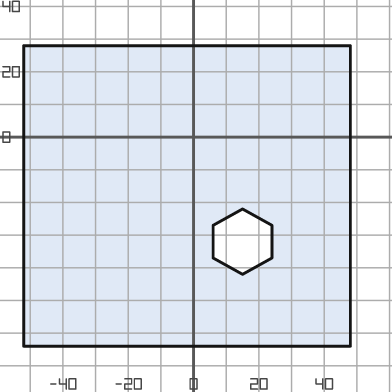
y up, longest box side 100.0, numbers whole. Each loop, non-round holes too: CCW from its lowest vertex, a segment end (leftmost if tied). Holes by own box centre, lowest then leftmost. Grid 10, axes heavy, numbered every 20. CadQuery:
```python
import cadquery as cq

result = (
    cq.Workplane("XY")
    .moveTo(-52.0, -64.0)
    .lineTo(48.0, -64.0)
    .lineTo(48.0, 28.0)
    .lineTo(-52.0, 28.0)
    .close()
    .moveTo(15.0, -42.0)
    .lineTo(24.0, -37.0)
    .lineTo(24.0, -27.0)
    .lineTo(15.0, -22.0)
    .lineTo(6.0, -27.0)
    .lineTo(6.0, -37.0)
    .close()
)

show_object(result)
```